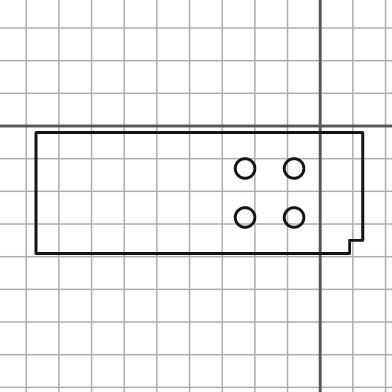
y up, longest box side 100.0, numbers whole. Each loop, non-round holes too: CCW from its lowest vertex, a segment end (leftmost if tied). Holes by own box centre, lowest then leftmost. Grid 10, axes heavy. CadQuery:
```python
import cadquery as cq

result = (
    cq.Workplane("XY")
    .moveTo(-87.0, -39.0)
    .lineTo(9.0, -39.0)
    .lineTo(9.0, -35.0)
    .lineTo(13.0, -35.0)
    .lineTo(13.0, -2.0)
    .lineTo(-87.0, -2.0)
    .close()
    .moveTo(-23.0, -28.0)
    .circle(3.0)
    .moveTo(-8.0, -28.0)
    .circle(3.0)
    .moveTo(-23.0, -13.0)
    .circle(3.0)
    .moveTo(-8.0, -13.0)
    .circle(3.0)
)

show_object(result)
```